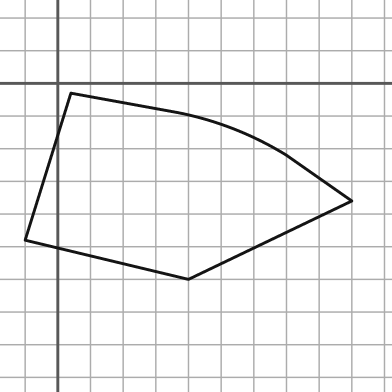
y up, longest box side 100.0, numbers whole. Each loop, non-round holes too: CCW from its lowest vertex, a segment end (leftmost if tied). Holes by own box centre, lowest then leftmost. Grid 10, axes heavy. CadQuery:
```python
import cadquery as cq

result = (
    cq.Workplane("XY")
    .moveTo(40.0, -60.0)
    .lineTo(90.0, -36.0)
    .lineTo(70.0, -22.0)
    .threePointArc((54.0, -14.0), (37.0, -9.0))
    .lineTo(4.0, -3.0)
    .lineTo(-10.0, -48.0)
    .close()
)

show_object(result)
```